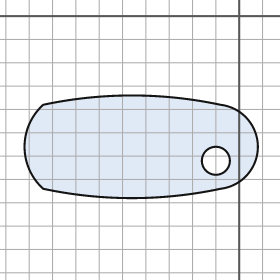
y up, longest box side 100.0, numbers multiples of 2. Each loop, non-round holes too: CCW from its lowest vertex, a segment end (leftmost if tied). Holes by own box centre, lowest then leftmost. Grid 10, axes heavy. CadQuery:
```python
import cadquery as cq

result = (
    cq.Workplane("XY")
    .moveTo(-84.0, -74.0)
    .threePointArc((-46.0, -78.0), (-8.0, -74.0))
    .threePointArc((8.0, -56.0), (-8.0, -38.0))
    .threePointArc((-46.0, -34.0), (-84.0, -38.0))
    .threePointArc((-92.0, -56.0), (-84.0, -74.0))
    .close()
    .moveTo(-10.0, -62.0)
    .circle(6.0)
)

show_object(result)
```